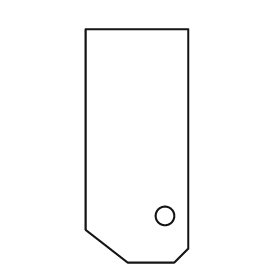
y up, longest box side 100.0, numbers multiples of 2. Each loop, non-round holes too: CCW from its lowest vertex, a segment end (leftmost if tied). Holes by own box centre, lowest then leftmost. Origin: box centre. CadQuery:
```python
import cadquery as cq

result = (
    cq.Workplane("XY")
    .moveTo(-4.0, -50.0)
    .lineTo(16.0, -50.0)
    .lineTo(22.0, -44.0)
    .lineTo(22.0, 50.0)
    .lineTo(-22.0, 50.0)
    .lineTo(-22.0, -36.0)
    .close()
    .moveTo(12.0, -30.0)
    .circle(4.0)
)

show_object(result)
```